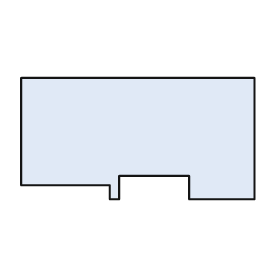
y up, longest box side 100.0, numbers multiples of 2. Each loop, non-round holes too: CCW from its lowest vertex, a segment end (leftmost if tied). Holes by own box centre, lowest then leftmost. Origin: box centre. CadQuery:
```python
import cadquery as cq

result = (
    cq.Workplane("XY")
    .moveTo(-12.0, -26.0)
    .lineTo(-8.0, -26.0)
    .lineTo(-8.0, -16.0)
    .lineTo(22.0, -16.0)
    .lineTo(22.0, -26.0)
    .lineTo(50.0, -26.0)
    .lineTo(50.0, 26.0)
    .lineTo(-50.0, 26.0)
    .lineTo(-50.0, -20.0)
    .lineTo(-12.0, -20.0)
    .close()
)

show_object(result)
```